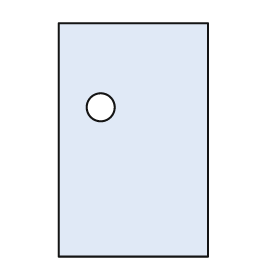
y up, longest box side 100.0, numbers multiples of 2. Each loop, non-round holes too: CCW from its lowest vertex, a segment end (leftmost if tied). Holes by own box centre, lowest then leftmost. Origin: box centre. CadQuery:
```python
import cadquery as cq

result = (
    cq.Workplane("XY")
    .moveTo(-32.0, -50.0)
    .lineTo(32.0, -50.0)
    .lineTo(32.0, 50.0)
    .lineTo(-32.0, 50.0)
    .close()
    .moveTo(-14.0, 14.0)
    .circle(6.0)
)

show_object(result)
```